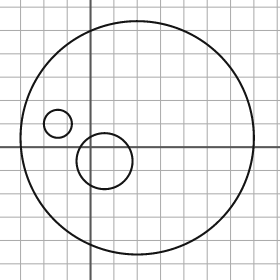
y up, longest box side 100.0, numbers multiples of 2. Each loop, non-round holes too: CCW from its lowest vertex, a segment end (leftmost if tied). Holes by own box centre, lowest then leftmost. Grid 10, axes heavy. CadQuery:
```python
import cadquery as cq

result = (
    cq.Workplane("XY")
    .moveTo(20.0, 4.0)
    .circle(50.0)
    .moveTo(6.0, -6.0)
    .circle(12.0)
    .moveTo(-14.0, 10.0)
    .circle(6.0)
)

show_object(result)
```